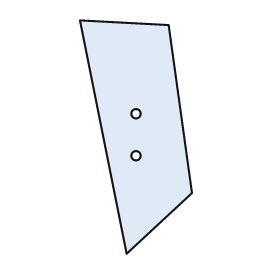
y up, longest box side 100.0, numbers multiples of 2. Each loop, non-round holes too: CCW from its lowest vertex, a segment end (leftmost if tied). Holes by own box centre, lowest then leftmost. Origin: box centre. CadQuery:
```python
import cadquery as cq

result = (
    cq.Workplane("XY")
    .moveTo(-4.0, -50.0)
    .lineTo(24.0, -24.0)
    .lineTo(14.0, 48.0)
    .lineTo(-24.0, 50.0)
    .close()
    .moveTo(0.0, -8.0)
    .circle(2.0)
    .moveTo(0.0, 10.0)
    .circle(2.0)
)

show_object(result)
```